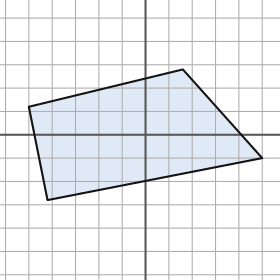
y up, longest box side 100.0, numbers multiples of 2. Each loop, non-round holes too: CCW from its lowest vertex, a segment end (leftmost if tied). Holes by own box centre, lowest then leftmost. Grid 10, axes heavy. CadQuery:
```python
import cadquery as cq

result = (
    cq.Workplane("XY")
    .moveTo(-42.0, -28.0)
    .lineTo(50.0, -10.0)
    .lineTo(16.0, 28.0)
    .lineTo(-50.0, 12.0)
    .close()
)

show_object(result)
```